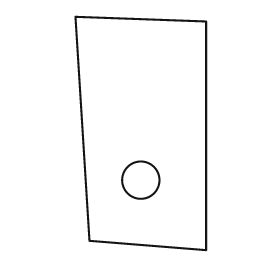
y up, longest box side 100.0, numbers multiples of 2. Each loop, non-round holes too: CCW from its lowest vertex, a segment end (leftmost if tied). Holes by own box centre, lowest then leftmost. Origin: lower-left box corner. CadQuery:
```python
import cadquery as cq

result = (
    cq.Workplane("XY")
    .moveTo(56.0, 0.0)
    .lineTo(56.0, 98.0)
    .lineTo(0.0, 100.0)
    .lineTo(6.0, 4.0)
    .close()
    .moveTo(28.0, 30.0)
    .circle(8.0)
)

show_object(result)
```